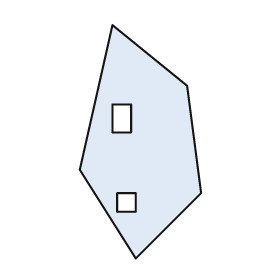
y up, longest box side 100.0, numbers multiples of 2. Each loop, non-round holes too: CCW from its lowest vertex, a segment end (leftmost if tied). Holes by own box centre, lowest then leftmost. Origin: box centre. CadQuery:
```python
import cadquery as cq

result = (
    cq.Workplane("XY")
    .moveTo(-2.0, -50.0)
    .lineTo(26.0, -22.0)
    .lineTo(20.0, 24.0)
    .lineTo(-12.0, 50.0)
    .lineTo(-26.0, -12.0)
    .close()
    .moveTo(-10.0, -30.0)
    .lineTo(-2.0, -30.0)
    .lineTo(-2.0, -22.0)
    .lineTo(-10.0, -22.0)
    .close()
    .moveTo(-12.0, 4.0)
    .lineTo(-4.0, 4.0)
    .lineTo(-4.0, 16.0)
    .lineTo(-12.0, 16.0)
    .close()
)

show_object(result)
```